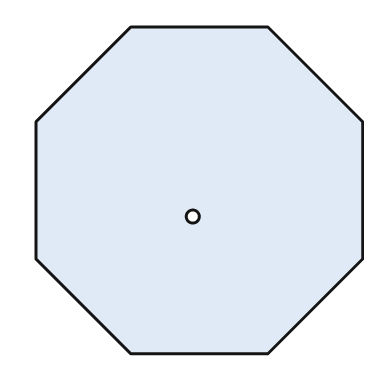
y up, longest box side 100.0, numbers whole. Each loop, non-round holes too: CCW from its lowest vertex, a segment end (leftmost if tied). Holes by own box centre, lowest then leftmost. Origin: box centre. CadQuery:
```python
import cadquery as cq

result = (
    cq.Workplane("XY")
    .moveTo(-21.0, -50.0)
    .lineTo(21.0, -50.0)
    .lineTo(50.0, -21.0)
    .lineTo(50.0, 21.0)
    .lineTo(21.0, 50.0)
    .lineTo(-21.0, 50.0)
    .lineTo(-50.0, 21.0)
    .lineTo(-50.0, -21.0)
    .close()
    .moveTo(-2.0, -8.0)
    .circle(2.0)
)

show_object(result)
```